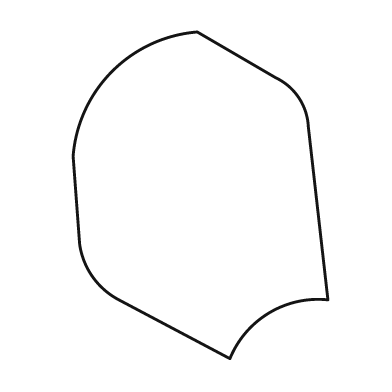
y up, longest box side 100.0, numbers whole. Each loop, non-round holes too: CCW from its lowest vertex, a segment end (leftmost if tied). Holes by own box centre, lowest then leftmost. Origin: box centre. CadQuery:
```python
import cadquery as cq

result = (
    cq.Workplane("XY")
    .moveTo(9.0, -50.0)
    .threePointArc((21.0, -36.0), (39.0, -32.0))
    .lineTo(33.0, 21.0)
    .threePointArc((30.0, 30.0), (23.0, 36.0))
    .lineTo(-1.0, 50.0)
    .threePointArc((-27.0, 38.0), (-39.0, 12.0))
    .lineTo(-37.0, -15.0)
    .threePointArc((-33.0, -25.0), (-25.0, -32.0))
    .close()
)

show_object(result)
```